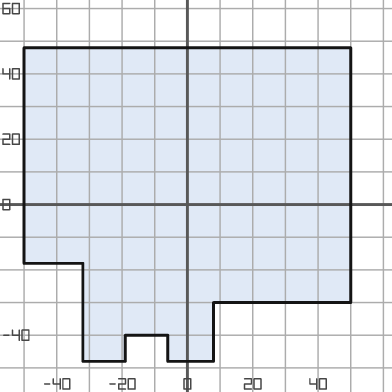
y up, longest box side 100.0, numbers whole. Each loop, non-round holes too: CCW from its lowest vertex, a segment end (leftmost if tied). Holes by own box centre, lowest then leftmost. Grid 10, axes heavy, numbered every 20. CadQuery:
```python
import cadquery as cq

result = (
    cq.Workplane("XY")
    .moveTo(-32.0, -48.0)
    .lineTo(-19.0, -48.0)
    .lineTo(-19.0, -40.0)
    .lineTo(-6.0, -40.0)
    .lineTo(-6.0, -48.0)
    .lineTo(8.0, -48.0)
    .lineTo(8.0, -30.0)
    .lineTo(50.0, -30.0)
    .lineTo(50.0, 48.0)
    .lineTo(-50.0, 48.0)
    .lineTo(-50.0, -18.0)
    .lineTo(-32.0, -18.0)
    .close()
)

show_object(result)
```